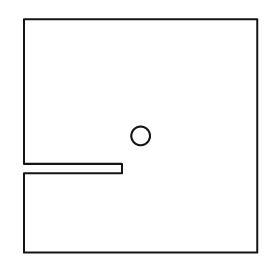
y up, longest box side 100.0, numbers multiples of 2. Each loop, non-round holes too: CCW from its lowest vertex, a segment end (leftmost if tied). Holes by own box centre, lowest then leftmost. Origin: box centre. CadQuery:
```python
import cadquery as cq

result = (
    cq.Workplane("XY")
    .moveTo(-50.0, -50.0)
    .lineTo(50.0, -50.0)
    .lineTo(50.0, 50.0)
    .lineTo(-50.0, 50.0)
    .lineTo(-50.0, -12.0)
    .lineTo(-8.0, -12.0)
    .lineTo(-8.0, -16.0)
    .lineTo(-50.0, -16.0)
    .close()
    .moveTo(0.0, 0.0)
    .circle(4.0)
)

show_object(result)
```